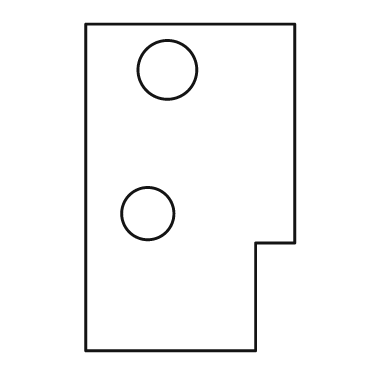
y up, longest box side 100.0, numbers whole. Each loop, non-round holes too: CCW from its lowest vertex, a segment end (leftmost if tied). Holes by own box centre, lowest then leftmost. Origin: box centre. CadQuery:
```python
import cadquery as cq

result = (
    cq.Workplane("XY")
    .moveTo(-32.0, -50.0)
    .lineTo(20.0, -50.0)
    .lineTo(20.0, -17.0)
    .lineTo(32.0, -17.0)
    .lineTo(32.0, 50.0)
    .lineTo(-32.0, 50.0)
    .close()
    .moveTo(-13.0, -8.0)
    .circle(8.0)
    .moveTo(-7.0, 36.0)
    .circle(9.0)
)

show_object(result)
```